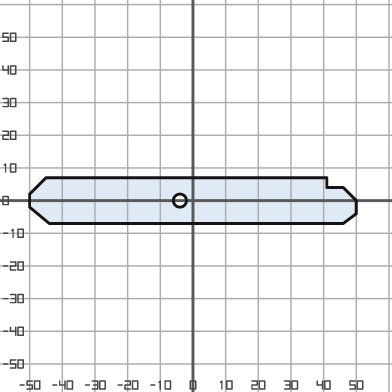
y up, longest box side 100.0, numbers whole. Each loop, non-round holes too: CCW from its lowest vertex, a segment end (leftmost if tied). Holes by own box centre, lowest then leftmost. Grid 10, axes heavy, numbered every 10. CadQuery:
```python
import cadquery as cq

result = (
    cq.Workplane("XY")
    .moveTo(-44.0, -7.0)
    .lineTo(46.0, -7.0)
    .lineTo(50.0, -4.0)
    .lineTo(50.0, 0.0)
    .lineTo(46.0, 4.0)
    .lineTo(41.0, 4.0)
    .lineTo(41.0, 7.0)
    .lineTo(-45.0, 7.0)
    .lineTo(-50.0, 2.0)
    .lineTo(-50.0, -2.0)
    .close()
    .moveTo(-4.0, 0.0)
    .circle(2.0)
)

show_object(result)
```